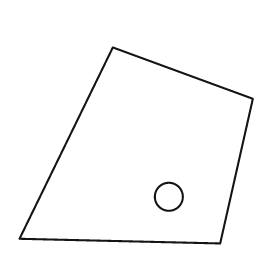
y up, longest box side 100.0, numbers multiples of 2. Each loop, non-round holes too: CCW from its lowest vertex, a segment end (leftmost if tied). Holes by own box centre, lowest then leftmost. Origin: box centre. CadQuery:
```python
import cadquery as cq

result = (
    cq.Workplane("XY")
    .moveTo(36.0, -42.0)
    .lineTo(50.0, 20.0)
    .lineTo(-10.0, 42.0)
    .lineTo(-50.0, -40.0)
    .close()
    .moveTo(14.0, -22.0)
    .circle(6.0)
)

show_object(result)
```